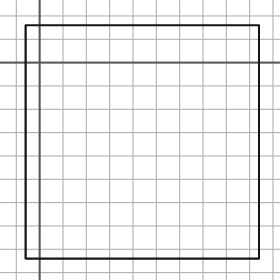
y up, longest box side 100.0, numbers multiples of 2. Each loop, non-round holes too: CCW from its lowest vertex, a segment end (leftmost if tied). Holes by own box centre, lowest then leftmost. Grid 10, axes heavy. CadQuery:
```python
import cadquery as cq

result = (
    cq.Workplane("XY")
    .moveTo(-6.0, -84.0)
    .lineTo(94.0, -84.0)
    .lineTo(94.0, 16.0)
    .lineTo(-6.0, 16.0)
    .close()
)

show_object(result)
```